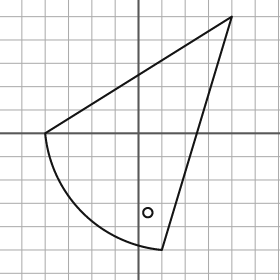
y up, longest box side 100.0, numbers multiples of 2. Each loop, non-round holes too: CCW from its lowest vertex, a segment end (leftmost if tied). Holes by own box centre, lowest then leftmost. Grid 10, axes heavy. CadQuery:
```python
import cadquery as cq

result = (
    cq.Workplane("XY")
    .moveTo(10.0, -50.0)
    .lineTo(40.0, 50.0)
    .lineTo(-40.0, 0.0)
    .threePointArc((-24.0, -34.0), (10.0, -50.0))
    .close()
    .moveTo(4.0, -34.0)
    .circle(2.0)
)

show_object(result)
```